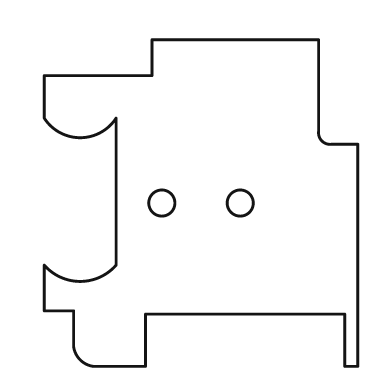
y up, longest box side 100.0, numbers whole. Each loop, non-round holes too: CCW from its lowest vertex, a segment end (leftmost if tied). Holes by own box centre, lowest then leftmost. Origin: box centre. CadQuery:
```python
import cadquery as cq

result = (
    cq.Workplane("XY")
    .moveTo(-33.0, -50.0)
    .lineTo(-17.0, -50.0)
    .lineTo(-17.0, -34.0)
    .lineTo(44.0, -34.0)
    .lineTo(44.0, -50.0)
    .lineTo(48.0, -50.0)
    .lineTo(48.0, 18.0)
    .lineTo(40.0, 18.0)
    .threePointArc((37.0, 19.0), (36.0, 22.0))
    .lineTo(36.0, 50.0)
    .lineTo(-15.0, 50.0)
    .lineTo(-15.0, 39.0)
    .lineTo(-48.0, 39.0)
    .lineTo(-48.0, 26.0)
    .threePointArc((-37.0, 20.0), (-26.0, 26.0))
    .lineTo(-26.0, -19.0)
    .threePointArc((-37.0, -24.0), (-48.0, -19.0))
    .lineTo(-48.0, -33.0)
    .lineTo(-39.0, -33.0)
    .lineTo(-39.0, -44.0)
    .threePointArc((-37.0, -48.0), (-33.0, -50.0))
    .close()
    .moveTo(-12.0, 0.0)
    .circle(4.0)
    .moveTo(12.0, 0.0)
    .circle(4.0)
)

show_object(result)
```